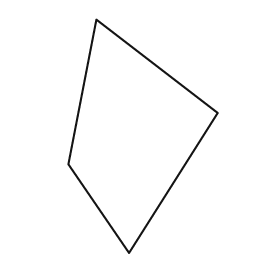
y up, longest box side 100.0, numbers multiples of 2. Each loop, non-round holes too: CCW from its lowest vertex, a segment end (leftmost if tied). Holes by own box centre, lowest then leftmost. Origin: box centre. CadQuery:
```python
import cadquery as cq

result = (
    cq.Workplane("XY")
    .moveTo(-6.0, -50.0)
    .lineTo(32.0, 10.0)
    .lineTo(-20.0, 50.0)
    .lineTo(-32.0, -12.0)
    .close()
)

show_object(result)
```